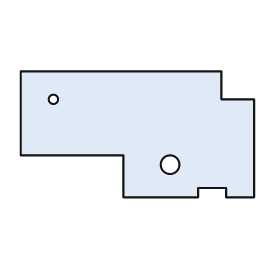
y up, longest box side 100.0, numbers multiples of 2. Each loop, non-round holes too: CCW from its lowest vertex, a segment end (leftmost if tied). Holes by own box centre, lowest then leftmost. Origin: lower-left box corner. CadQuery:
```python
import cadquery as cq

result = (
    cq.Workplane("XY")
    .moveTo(44.0, 0.0)
    .lineTo(76.0, 0.0)
    .lineTo(76.0, 4.0)
    .lineTo(88.0, 4.0)
    .lineTo(88.0, 0.0)
    .lineTo(100.0, 0.0)
    .lineTo(100.0, 42.0)
    .lineTo(86.0, 42.0)
    .lineTo(86.0, 54.0)
    .lineTo(0.0, 54.0)
    .lineTo(0.0, 18.0)
    .lineTo(44.0, 18.0)
    .close()
    .moveTo(64.0, 14.0)
    .circle(4.0)
    .moveTo(14.0, 42.0)
    .circle(2.0)
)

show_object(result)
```